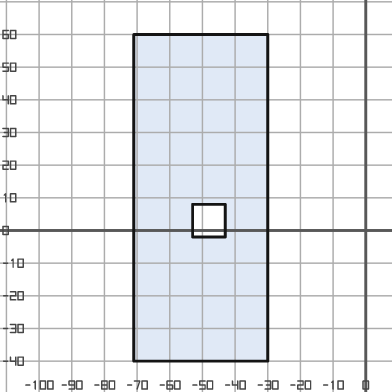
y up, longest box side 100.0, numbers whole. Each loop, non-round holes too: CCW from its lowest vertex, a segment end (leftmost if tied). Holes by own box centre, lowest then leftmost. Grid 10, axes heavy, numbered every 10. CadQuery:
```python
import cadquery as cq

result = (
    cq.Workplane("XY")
    .moveTo(-71.0, -40.0)
    .lineTo(-30.0, -40.0)
    .lineTo(-30.0, 60.0)
    .lineTo(-71.0, 60.0)
    .close()
    .moveTo(-53.0, -2.0)
    .lineTo(-43.0, -2.0)
    .lineTo(-43.0, 8.0)
    .lineTo(-53.0, 8.0)
    .close()
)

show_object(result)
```